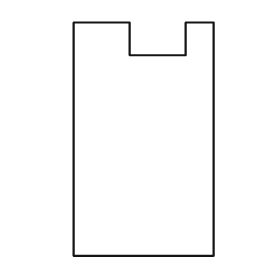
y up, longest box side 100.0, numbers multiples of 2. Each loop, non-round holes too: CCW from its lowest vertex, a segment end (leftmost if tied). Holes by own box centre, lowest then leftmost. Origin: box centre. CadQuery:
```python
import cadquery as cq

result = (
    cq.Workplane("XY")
    .moveTo(-30.0, -50.0)
    .lineTo(30.0, -50.0)
    .lineTo(30.0, 50.0)
    .lineTo(18.0, 50.0)
    .lineTo(18.0, 36.0)
    .lineTo(-6.0, 36.0)
    .lineTo(-6.0, 50.0)
    .lineTo(-30.0, 50.0)
    .close()
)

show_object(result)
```